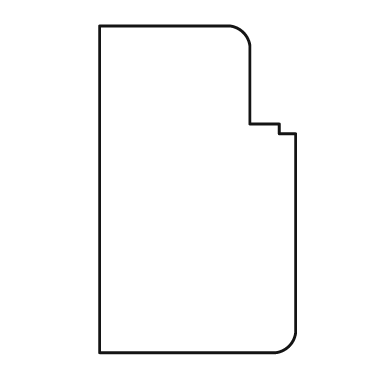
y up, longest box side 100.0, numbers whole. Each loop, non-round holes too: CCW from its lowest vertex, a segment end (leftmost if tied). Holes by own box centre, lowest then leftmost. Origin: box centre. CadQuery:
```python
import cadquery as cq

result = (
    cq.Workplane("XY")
    .moveTo(-30.0, -50.0)
    .lineTo(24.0, -50.0)
    .threePointArc((28.0, -48.0), (30.0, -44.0))
    .lineTo(30.0, 17.0)
    .lineTo(25.0, 17.0)
    .lineTo(25.0, 20.0)
    .lineTo(16.0, 20.0)
    .lineTo(16.0, 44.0)
    .threePointArc((14.0, 48.0), (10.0, 50.0))
    .lineTo(-30.0, 50.0)
    .close()
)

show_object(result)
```